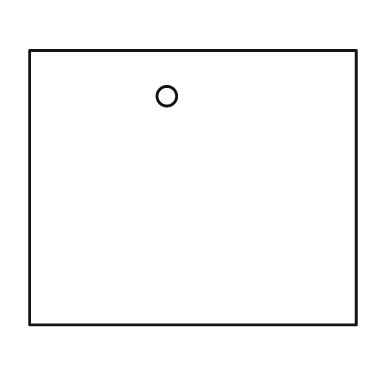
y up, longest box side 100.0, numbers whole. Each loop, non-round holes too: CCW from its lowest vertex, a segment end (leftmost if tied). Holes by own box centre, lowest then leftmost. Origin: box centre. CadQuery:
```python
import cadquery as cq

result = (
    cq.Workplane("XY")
    .moveTo(-50.0, -42.0)
    .lineTo(50.0, -42.0)
    .lineTo(50.0, 42.0)
    .lineTo(-50.0, 42.0)
    .close()
    .moveTo(-8.0, 28.0)
    .circle(3.0)
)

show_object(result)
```